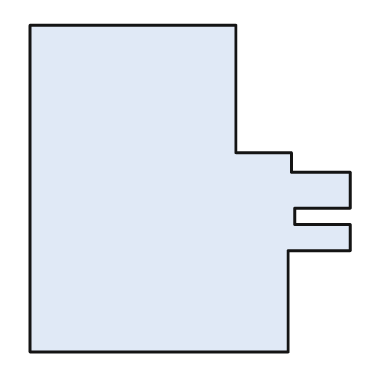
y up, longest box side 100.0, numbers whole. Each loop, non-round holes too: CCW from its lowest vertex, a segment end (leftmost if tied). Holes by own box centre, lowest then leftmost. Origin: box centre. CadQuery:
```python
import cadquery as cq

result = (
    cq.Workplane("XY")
    .moveTo(-49.0, -50.0)
    .lineTo(30.0, -50.0)
    .lineTo(30.0, -19.0)
    .lineTo(49.0, -19.0)
    .lineTo(49.0, -11.0)
    .lineTo(32.0, -11.0)
    .lineTo(32.0, -6.0)
    .lineTo(49.0, -6.0)
    .lineTo(49.0, 5.0)
    .lineTo(31.0, 5.0)
    .lineTo(31.0, 11.0)
    .lineTo(14.0, 11.0)
    .lineTo(14.0, 50.0)
    .lineTo(-49.0, 50.0)
    .close()
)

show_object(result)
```